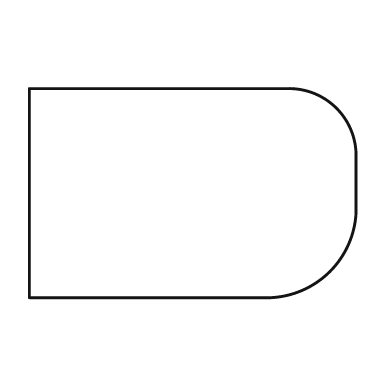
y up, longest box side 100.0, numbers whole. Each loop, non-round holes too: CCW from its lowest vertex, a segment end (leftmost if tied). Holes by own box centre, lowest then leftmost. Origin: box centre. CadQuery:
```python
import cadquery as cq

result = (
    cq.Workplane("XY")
    .moveTo(-50.0, -32.0)
    .lineTo(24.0, -32.0)
    .threePointArc((42.0, -24.0), (50.0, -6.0))
    .lineTo(50.0, 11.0)
    .threePointArc((44.0, 26.0), (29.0, 32.0))
    .lineTo(-50.0, 32.0)
    .close()
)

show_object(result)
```